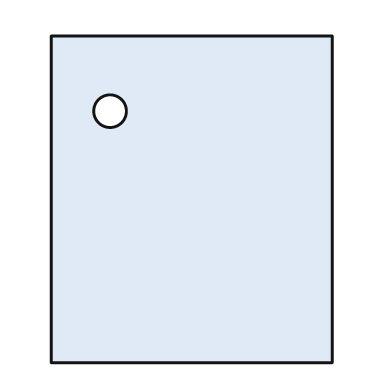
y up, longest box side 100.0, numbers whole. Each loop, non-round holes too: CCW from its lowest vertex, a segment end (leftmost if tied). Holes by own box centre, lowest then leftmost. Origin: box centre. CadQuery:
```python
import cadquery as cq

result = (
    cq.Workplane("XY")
    .moveTo(-43.0, -50.0)
    .lineTo(43.0, -50.0)
    .lineTo(43.0, 50.0)
    .lineTo(-43.0, 50.0)
    .close()
    .moveTo(-25.0, 27.0)
    .circle(5.0)
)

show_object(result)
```